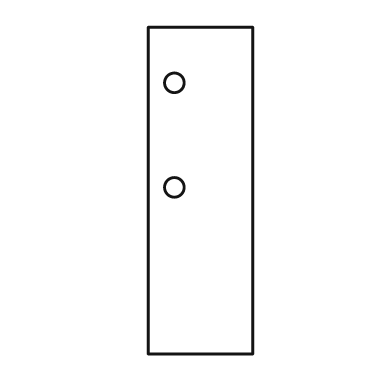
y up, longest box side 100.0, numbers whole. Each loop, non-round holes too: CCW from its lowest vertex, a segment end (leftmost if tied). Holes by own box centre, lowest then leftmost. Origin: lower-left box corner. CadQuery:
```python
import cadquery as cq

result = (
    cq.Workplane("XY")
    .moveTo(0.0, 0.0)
    .lineTo(32.0, 0.0)
    .lineTo(32.0, 100.0)
    .lineTo(0.0, 100.0)
    .close()
    .moveTo(8.0, 51.0)
    .circle(3.0)
    .moveTo(8.0, 83.0)
    .circle(3.0)
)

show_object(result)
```